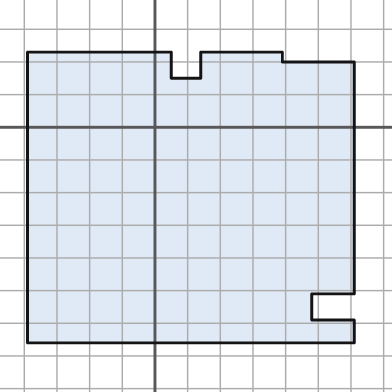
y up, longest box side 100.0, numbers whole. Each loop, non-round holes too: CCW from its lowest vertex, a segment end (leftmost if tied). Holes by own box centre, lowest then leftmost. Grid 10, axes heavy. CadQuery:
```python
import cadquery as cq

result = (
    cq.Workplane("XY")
    .moveTo(-39.0, -66.0)
    .lineTo(61.0, -66.0)
    .lineTo(61.0, -59.0)
    .lineTo(48.0, -59.0)
    .lineTo(48.0, -51.0)
    .lineTo(61.0, -51.0)
    .lineTo(61.0, 20.0)
    .lineTo(39.0, 20.0)
    .lineTo(39.0, 23.0)
    .lineTo(14.0, 23.0)
    .lineTo(14.0, 15.0)
    .lineTo(5.0, 15.0)
    .lineTo(5.0, 23.0)
    .lineTo(-39.0, 23.0)
    .close()
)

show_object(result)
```